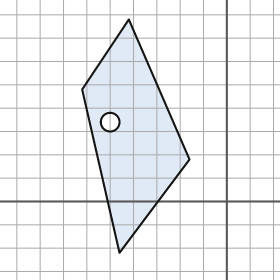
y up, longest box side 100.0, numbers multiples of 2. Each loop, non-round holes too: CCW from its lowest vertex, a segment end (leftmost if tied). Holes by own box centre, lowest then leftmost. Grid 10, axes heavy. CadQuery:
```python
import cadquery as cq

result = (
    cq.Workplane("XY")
    .moveTo(-46.0, -22.0)
    .lineTo(-16.0, 18.0)
    .lineTo(-42.0, 78.0)
    .lineTo(-62.0, 48.0)
    .close()
    .moveTo(-50.0, 34.0)
    .circle(4.0)
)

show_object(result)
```